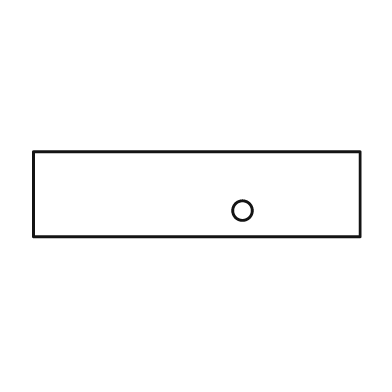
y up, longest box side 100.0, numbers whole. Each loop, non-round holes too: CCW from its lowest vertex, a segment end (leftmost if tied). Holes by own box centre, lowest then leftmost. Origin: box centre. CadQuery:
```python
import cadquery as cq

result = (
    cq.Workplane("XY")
    .moveTo(-50.0, -13.0)
    .lineTo(50.0, -13.0)
    .lineTo(50.0, 13.0)
    .lineTo(-50.0, 13.0)
    .close()
    .moveTo(14.0, -5.0)
    .circle(3.0)
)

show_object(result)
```